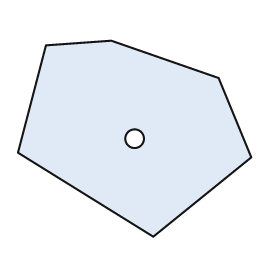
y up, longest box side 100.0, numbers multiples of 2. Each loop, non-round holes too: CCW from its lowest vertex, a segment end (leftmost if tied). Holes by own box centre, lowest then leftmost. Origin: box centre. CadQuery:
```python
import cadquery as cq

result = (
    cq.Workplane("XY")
    .moveTo(8.0, -42.0)
    .lineTo(50.0, -8.0)
    .lineTo(36.0, 26.0)
    .lineTo(-10.0, 42.0)
    .lineTo(-38.0, 40.0)
    .lineTo(-50.0, -6.0)
    .close()
    .moveTo(0.0, 0.0)
    .circle(4.0)
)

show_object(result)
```